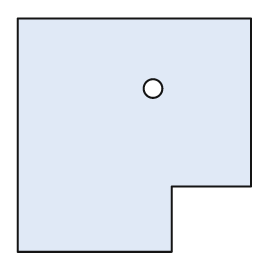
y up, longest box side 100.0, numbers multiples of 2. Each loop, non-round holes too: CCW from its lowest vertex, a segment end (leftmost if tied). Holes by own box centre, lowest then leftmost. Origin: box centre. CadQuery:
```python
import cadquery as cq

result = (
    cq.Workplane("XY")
    .moveTo(-50.0, -50.0)
    .lineTo(16.0, -50.0)
    .lineTo(16.0, -22.0)
    .lineTo(50.0, -22.0)
    .lineTo(50.0, 50.0)
    .lineTo(-50.0, 50.0)
    .close()
    .moveTo(8.0, 20.0)
    .circle(4.0)
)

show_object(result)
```